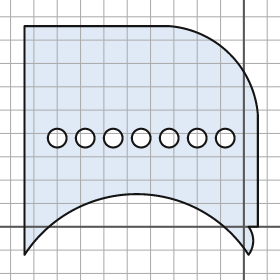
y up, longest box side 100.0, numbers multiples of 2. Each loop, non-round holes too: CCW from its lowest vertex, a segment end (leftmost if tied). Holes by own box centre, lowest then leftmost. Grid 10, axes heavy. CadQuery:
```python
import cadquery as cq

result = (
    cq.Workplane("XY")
    .moveTo(-94.0, -12.0)
    .threePointArc((-46.0, 14.0), (2.0, -12.0))
    .threePointArc((4.0, -6.0), (2.0, 0.0))
    .lineTo(6.0, 0.0)
    .lineTo(6.0, 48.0)
    .threePointArc((-6.0, 74.0), (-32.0, 86.0))
    .lineTo(-94.0, 86.0)
    .close()
    .moveTo(-80.0, 38.0)
    .circle(4.0)
    .moveTo(-68.0, 38.0)
    .circle(4.0)
    .moveTo(-56.0, 38.0)
    .circle(4.0)
    .moveTo(-44.0, 38.0)
    .circle(4.0)
    .moveTo(-32.0, 38.0)
    .circle(4.0)
    .moveTo(-20.0, 38.0)
    .circle(4.0)
    .moveTo(-8.0, 38.0)
    .circle(4.0)
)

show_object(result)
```